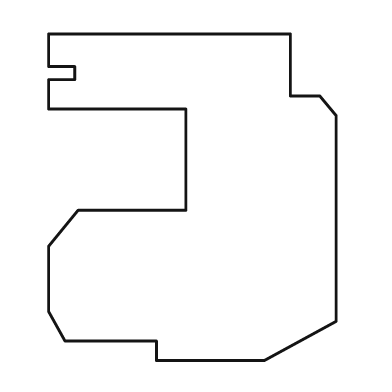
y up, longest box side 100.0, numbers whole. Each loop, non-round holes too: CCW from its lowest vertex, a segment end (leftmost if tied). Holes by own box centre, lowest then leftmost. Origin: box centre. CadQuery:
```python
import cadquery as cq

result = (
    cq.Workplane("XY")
    .moveTo(-11.0, -50.0)
    .lineTo(22.0, -50.0)
    .lineTo(44.0, -38.0)
    .lineTo(44.0, 25.0)
    .lineTo(39.0, 31.0)
    .lineTo(30.0, 31.0)
    .lineTo(30.0, 50.0)
    .lineTo(-44.0, 50.0)
    .lineTo(-44.0, 40.0)
    .lineTo(-36.0, 40.0)
    .lineTo(-36.0, 36.0)
    .lineTo(-44.0, 36.0)
    .lineTo(-44.0, 27.0)
    .lineTo(-2.0, 27.0)
    .lineTo(-2.0, -4.0)
    .lineTo(-35.0, -4.0)
    .lineTo(-44.0, -15.0)
    .lineTo(-44.0, -35.0)
    .lineTo(-39.0, -44.0)
    .lineTo(-11.0, -44.0)
    .close()
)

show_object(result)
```